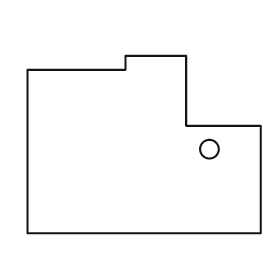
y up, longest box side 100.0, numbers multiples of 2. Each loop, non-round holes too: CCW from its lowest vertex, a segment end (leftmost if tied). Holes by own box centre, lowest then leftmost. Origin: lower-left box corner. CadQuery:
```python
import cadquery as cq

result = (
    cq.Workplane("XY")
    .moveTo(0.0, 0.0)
    .lineTo(100.0, 0.0)
    .lineTo(100.0, 46.0)
    .lineTo(68.0, 46.0)
    .lineTo(68.0, 76.0)
    .lineTo(42.0, 76.0)
    .lineTo(42.0, 70.0)
    .lineTo(0.0, 70.0)
    .close()
    .moveTo(78.0, 36.0)
    .circle(4.0)
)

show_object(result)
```